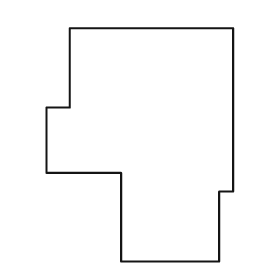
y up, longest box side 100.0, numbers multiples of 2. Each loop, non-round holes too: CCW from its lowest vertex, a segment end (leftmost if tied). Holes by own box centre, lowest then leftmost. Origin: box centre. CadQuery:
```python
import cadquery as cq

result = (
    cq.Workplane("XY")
    .moveTo(-8.0, -50.0)
    .lineTo(34.0, -50.0)
    .lineTo(34.0, -20.0)
    .lineTo(40.0, -20.0)
    .lineTo(40.0, 50.0)
    .lineTo(-30.0, 50.0)
    .lineTo(-30.0, 16.0)
    .lineTo(-40.0, 16.0)
    .lineTo(-40.0, -12.0)
    .lineTo(-8.0, -12.0)
    .close()
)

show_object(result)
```